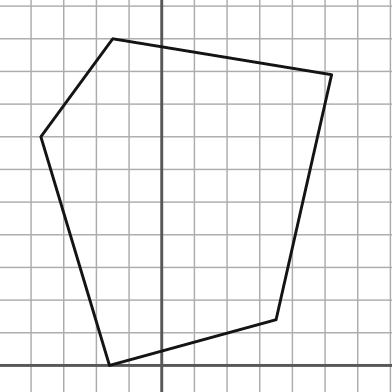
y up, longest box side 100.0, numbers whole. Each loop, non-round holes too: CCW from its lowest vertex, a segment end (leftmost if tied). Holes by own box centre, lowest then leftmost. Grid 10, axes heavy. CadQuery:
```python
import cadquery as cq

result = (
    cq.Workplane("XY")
    .moveTo(-16.0, 0.0)
    .lineTo(35.0, 14.0)
    .lineTo(52.0, 89.0)
    .lineTo(-15.0, 100.0)
    .lineTo(-37.0, 70.0)
    .close()
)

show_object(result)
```